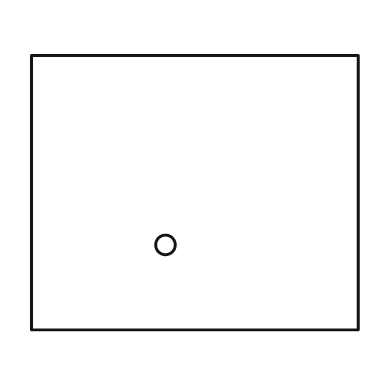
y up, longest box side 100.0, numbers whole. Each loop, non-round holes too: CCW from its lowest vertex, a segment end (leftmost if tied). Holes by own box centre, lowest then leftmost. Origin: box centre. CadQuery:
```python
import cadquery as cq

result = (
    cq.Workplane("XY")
    .moveTo(-50.0, -42.0)
    .lineTo(50.0, -42.0)
    .lineTo(50.0, 42.0)
    .lineTo(-50.0, 42.0)
    .close()
    .moveTo(-9.0, -16.0)
    .circle(3.0)
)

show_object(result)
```